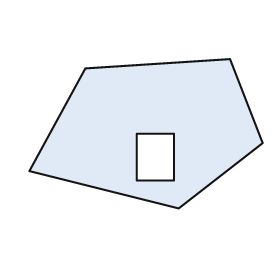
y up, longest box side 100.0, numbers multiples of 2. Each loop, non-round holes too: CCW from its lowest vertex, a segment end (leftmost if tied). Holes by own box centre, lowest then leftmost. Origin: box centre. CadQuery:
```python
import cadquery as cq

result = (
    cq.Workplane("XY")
    .moveTo(14.0, -32.0)
    .lineTo(50.0, -4.0)
    .lineTo(36.0, 32.0)
    .lineTo(-26.0, 28.0)
    .lineTo(-50.0, -16.0)
    .close()
    .moveTo(-4.0, -20.0)
    .lineTo(12.0, -20.0)
    .lineTo(12.0, 0.0)
    .lineTo(-4.0, 0.0)
    .close()
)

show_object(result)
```